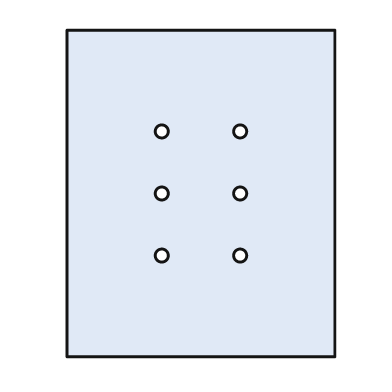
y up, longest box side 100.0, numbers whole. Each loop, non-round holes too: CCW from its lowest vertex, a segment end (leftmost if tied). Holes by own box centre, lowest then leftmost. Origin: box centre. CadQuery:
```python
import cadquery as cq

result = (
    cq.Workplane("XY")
    .moveTo(-41.0, -50.0)
    .lineTo(41.0, -50.0)
    .lineTo(41.0, 50.0)
    .lineTo(-41.0, 50.0)
    .close()
    .moveTo(-12.0, -19.0)
    .circle(2.0)
    .moveTo(12.0, -19.0)
    .circle(2.0)
    .moveTo(-12.0, 0.0)
    .circle(2.0)
    .moveTo(12.0, 0.0)
    .circle(2.0)
    .moveTo(-12.0, 19.0)
    .circle(2.0)
    .moveTo(12.0, 19.0)
    .circle(2.0)
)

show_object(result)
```